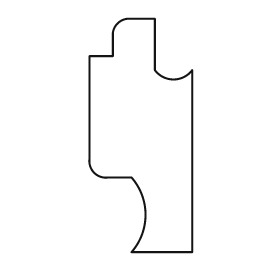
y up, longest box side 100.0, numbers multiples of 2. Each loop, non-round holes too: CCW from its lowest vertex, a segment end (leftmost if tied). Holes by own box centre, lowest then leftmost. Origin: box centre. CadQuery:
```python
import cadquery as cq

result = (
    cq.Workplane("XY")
    .moveTo(-4.0, -50.0)
    .lineTo(22.0, -50.0)
    .lineTo(22.0, 28.0)
    .threePointArc((14.0, 24.0), (6.0, 28.0))
    .lineTo(6.0, 50.0)
    .lineTo(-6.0, 50.0)
    .threePointArc((-10.0, 48.0), (-12.0, 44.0))
    .lineTo(-12.0, 34.0)
    .lineTo(-22.0, 34.0)
    .lineTo(-22.0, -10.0)
    .threePointArc((-20.0, -16.0), (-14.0, -18.0))
    .lineTo(-4.0, -18.0)
    .threePointArc((2.0, -34.0), (-4.0, -50.0))
    .close()
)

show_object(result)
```